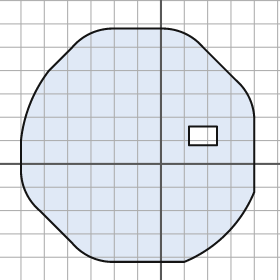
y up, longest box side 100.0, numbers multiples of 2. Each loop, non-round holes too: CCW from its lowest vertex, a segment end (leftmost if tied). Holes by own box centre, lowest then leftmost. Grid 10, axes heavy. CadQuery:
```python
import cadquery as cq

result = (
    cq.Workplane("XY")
    .moveTo(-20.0, -42.0)
    .lineTo(10.0, -42.0)
    .threePointArc((28.0, -30.0), (40.0, -12.0))
    .lineTo(40.0, 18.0)
    .threePointArc((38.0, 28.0), (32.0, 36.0))
    .lineTo(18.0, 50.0)
    .threePointArc((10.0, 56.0), (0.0, 58.0))
    .lineTo(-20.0, 58.0)
    .threePointArc((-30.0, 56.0), (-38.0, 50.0))
    .lineTo(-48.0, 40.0)
    .threePointArc((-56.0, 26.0), (-60.0, 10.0))
    .lineTo(-60.0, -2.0)
    .threePointArc((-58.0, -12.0), (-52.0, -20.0))
    .lineTo(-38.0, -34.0)
    .threePointArc((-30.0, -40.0), (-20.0, -42.0))
    .close()
    .moveTo(12.0, 8.0)
    .lineTo(24.0, 8.0)
    .lineTo(24.0, 16.0)
    .lineTo(12.0, 16.0)
    .close()
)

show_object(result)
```